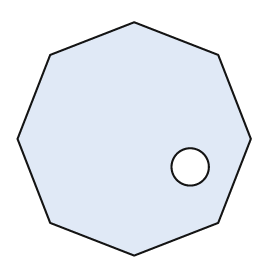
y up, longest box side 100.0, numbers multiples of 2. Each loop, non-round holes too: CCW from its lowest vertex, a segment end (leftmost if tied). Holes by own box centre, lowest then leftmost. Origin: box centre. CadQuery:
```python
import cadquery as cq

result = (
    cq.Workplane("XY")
    .moveTo(0.0, -50.0)
    .lineTo(36.0, -36.0)
    .lineTo(50.0, 0.0)
    .lineTo(36.0, 36.0)
    .lineTo(0.0, 50.0)
    .lineTo(-36.0, 36.0)
    .lineTo(-50.0, 0.0)
    .lineTo(-36.0, -36.0)
    .close()
    .moveTo(24.0, -12.0)
    .circle(8.0)
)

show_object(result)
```